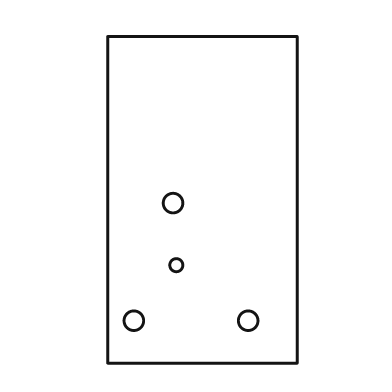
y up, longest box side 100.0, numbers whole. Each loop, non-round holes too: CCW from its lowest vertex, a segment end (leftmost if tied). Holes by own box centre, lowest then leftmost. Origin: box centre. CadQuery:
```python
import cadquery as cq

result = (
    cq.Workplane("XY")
    .moveTo(-29.0, -50.0)
    .lineTo(29.0, -50.0)
    .lineTo(29.0, 50.0)
    .lineTo(-29.0, 50.0)
    .close()
    .moveTo(-21.0, -37.0)
    .circle(3.0)
    .moveTo(14.0, -37.0)
    .circle(3.0)
    .moveTo(-8.0, -20.0)
    .circle(2.0)
    .moveTo(-9.0, -1.0)
    .circle(3.0)
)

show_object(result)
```